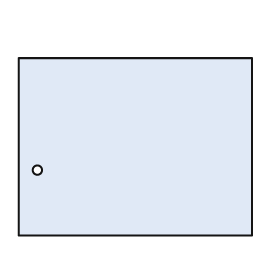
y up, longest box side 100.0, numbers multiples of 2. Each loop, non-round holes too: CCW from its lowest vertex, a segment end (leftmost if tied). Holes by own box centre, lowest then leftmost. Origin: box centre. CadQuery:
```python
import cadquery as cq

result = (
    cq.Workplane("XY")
    .moveTo(-50.0, -38.0)
    .lineTo(50.0, -38.0)
    .lineTo(50.0, 38.0)
    .lineTo(-50.0, 38.0)
    .close()
    .moveTo(-42.0, -10.0)
    .circle(2.0)
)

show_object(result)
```